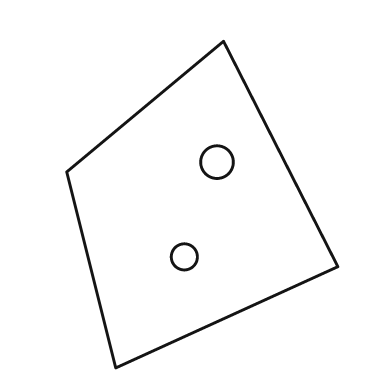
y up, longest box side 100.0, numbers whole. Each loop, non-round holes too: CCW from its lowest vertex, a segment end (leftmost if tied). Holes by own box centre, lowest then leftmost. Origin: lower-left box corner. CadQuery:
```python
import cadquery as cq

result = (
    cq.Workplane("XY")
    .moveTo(15.0, 0.0)
    .lineTo(83.0, 31.0)
    .lineTo(48.0, 100.0)
    .lineTo(0.0, 60.0)
    .close()
    .moveTo(36.0, 34.0)
    .circle(4.0)
    .moveTo(46.0, 63.0)
    .circle(5.0)
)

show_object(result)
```